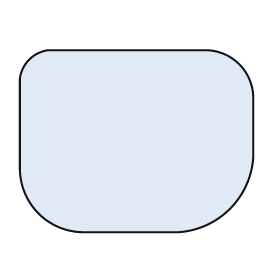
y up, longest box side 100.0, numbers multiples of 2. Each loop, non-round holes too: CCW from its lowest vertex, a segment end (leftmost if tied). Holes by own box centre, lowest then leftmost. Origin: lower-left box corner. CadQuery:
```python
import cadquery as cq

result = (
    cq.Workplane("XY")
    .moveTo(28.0, 0.0)
    .lineTo(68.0, 0.0)
    .threePointArc((90.0, 10.0), (100.0, 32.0))
    .lineTo(100.0, 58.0)
    .threePointArc((94.0, 72.0), (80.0, 78.0))
    .lineTo(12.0, 78.0)
    .threePointArc((4.0, 74.0), (0.0, 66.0))
    .lineTo(0.0, 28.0)
    .threePointArc((8.0, 8.0), (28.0, 0.0))
    .close()
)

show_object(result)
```